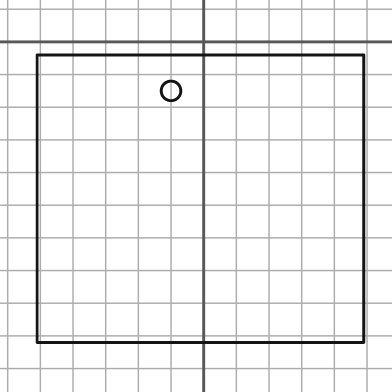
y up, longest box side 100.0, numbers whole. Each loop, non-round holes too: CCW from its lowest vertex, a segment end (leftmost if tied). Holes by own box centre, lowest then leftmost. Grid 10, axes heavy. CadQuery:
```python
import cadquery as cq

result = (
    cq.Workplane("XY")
    .moveTo(-51.0, -92.0)
    .lineTo(49.0, -92.0)
    .lineTo(49.0, -4.0)
    .lineTo(-51.0, -4.0)
    .close()
    .moveTo(-10.0, -15.0)
    .circle(3.0)
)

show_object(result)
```